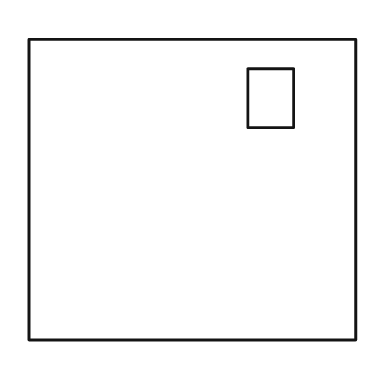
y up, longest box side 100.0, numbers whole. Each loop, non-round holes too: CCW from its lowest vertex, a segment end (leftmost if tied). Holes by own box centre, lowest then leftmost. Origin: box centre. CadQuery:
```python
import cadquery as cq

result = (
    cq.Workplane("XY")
    .moveTo(-50.0, -46.0)
    .lineTo(50.0, -46.0)
    .lineTo(50.0, 46.0)
    .lineTo(-50.0, 46.0)
    .close()
    .moveTo(17.0, 19.0)
    .lineTo(31.0, 19.0)
    .lineTo(31.0, 37.0)
    .lineTo(17.0, 37.0)
    .close()
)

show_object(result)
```